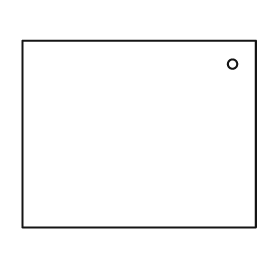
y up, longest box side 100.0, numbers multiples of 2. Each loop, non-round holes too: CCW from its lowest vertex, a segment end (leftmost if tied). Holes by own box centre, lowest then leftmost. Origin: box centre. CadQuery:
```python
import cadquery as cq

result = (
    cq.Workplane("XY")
    .moveTo(-50.0, -40.0)
    .lineTo(50.0, -40.0)
    .lineTo(50.0, 40.0)
    .lineTo(-50.0, 40.0)
    .close()
    .moveTo(40.0, 30.0)
    .circle(2.0)
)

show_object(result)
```